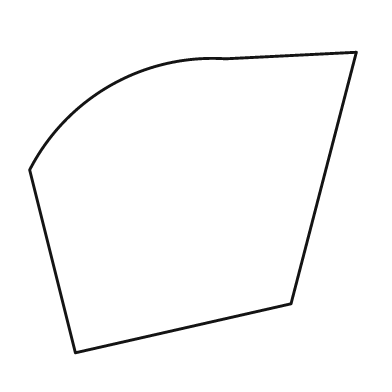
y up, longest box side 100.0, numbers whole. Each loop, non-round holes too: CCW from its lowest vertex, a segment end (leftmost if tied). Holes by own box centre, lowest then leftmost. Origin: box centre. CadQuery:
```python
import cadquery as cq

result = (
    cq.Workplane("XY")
    .moveTo(-36.0, -46.0)
    .lineTo(30.0, -31.0)
    .lineTo(50.0, 46.0)
    .lineTo(10.0, 44.0)
    .threePointArc((-25.0, 36.0), (-50.0, 10.0))
    .close()
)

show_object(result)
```